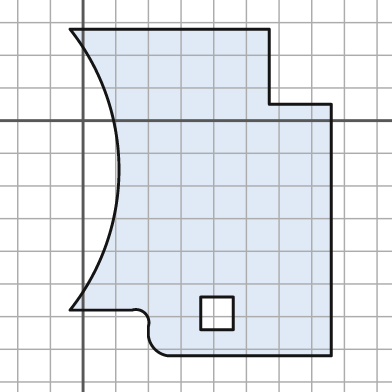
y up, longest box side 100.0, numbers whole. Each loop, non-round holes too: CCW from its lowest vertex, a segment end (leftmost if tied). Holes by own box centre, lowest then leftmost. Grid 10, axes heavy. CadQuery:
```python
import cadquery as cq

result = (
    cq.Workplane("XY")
    .moveTo(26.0, -72.0)
    .lineTo(76.0, -72.0)
    .lineTo(76.0, 5.0)
    .lineTo(57.0, 5.0)
    .lineTo(57.0, 28.0)
    .lineTo(-4.0, 28.0)
    .threePointArc((11.0, -15.0), (-4.0, -58.0))
    .lineTo(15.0, -58.0)
    .threePointArc((19.0, -59.0), (20.0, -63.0))
    .lineTo(20.0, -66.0)
    .threePointArc((22.0, -70.0), (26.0, -72.0))
    .close()
    .moveTo(36.0, -64.0)
    .lineTo(46.0, -64.0)
    .lineTo(46.0, -54.0)
    .lineTo(36.0, -54.0)
    .close()
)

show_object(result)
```